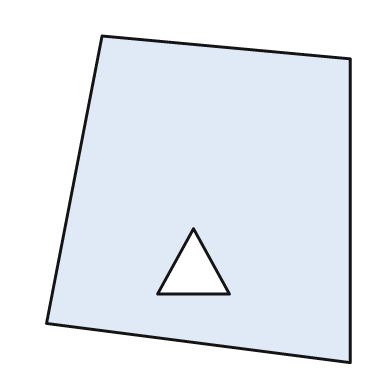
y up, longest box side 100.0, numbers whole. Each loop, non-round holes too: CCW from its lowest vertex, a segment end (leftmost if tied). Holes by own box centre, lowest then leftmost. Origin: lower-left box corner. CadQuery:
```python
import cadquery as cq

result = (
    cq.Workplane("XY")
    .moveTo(93.0, 0.0)
    .lineTo(93.0, 93.0)
    .lineTo(17.0, 100.0)
    .lineTo(0.0, 12.0)
    .close()
    .moveTo(34.0, 21.0)
    .lineTo(56.0, 21.0)
    .lineTo(45.0, 41.0)
    .close()
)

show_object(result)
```